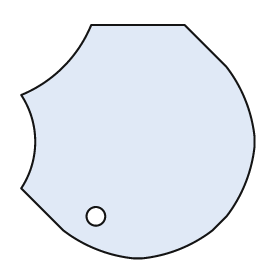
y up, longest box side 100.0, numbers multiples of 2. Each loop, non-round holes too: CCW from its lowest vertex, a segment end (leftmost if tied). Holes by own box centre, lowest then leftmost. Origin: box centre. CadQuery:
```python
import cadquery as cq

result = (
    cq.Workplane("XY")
    .moveTo(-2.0, -50.0)
    .lineTo(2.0, -50.0)
    .threePointArc((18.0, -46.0), (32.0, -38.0))
    .lineTo(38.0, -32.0)
    .threePointArc((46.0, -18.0), (50.0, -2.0))
    .lineTo(50.0, 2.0)
    .threePointArc((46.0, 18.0), (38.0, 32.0))
    .lineTo(20.0, 50.0)
    .lineTo(-20.0, 50.0)
    .threePointArc((-32.0, 32.0), (-50.0, 20.0))
    .threePointArc((-44.0, 0.0), (-50.0, -20.0))
    .lineTo(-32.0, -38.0)
    .threePointArc((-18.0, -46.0), (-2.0, -50.0))
    .close()
    .moveTo(-18.0, -32.0)
    .circle(4.0)
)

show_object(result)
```